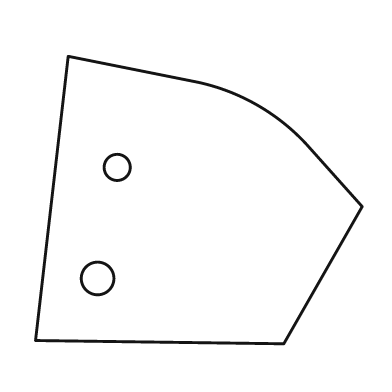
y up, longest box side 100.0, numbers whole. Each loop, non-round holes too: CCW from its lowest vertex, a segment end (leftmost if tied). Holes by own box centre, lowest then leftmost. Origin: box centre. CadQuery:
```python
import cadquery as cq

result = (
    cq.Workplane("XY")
    .moveTo(26.0, -44.0)
    .lineTo(50.0, -2.0)
    .lineTo(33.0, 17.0)
    .threePointArc((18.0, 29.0), (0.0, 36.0))
    .lineTo(-40.0, 44.0)
    .lineTo(-50.0, -43.0)
    .close()
    .moveTo(-31.0, -24.0)
    .circle(5.0)
    .moveTo(-25.0, 10.0)
    .circle(4.0)
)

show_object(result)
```